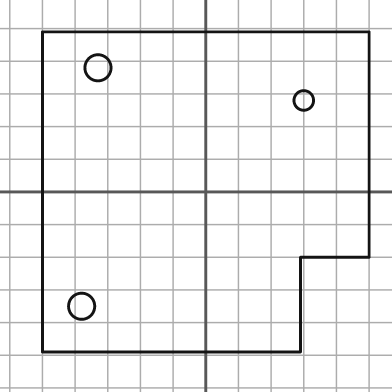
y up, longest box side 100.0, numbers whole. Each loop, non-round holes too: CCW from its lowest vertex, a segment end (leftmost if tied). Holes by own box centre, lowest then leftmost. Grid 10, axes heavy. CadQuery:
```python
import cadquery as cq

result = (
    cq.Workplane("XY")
    .moveTo(-50.0, -49.0)
    .lineTo(29.0, -49.0)
    .lineTo(29.0, -20.0)
    .lineTo(50.0, -20.0)
    .lineTo(50.0, 49.0)
    .lineTo(-50.0, 49.0)
    .close()
    .moveTo(-38.0, -35.0)
    .circle(4.0)
    .moveTo(30.0, 28.0)
    .circle(3.0)
    .moveTo(-33.0, 38.0)
    .circle(4.0)
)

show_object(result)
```